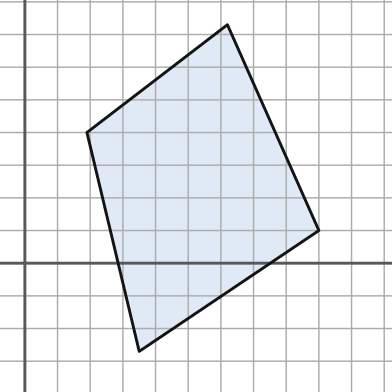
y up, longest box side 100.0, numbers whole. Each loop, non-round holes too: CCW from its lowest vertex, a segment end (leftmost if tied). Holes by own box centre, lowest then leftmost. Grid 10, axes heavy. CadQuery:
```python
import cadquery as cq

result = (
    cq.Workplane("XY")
    .moveTo(35.0, -27.0)
    .lineTo(90.0, 10.0)
    .lineTo(62.0, 73.0)
    .lineTo(19.0, 40.0)
    .close()
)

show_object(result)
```